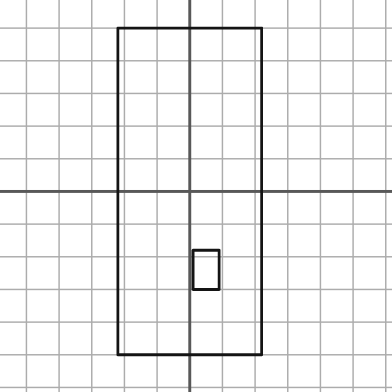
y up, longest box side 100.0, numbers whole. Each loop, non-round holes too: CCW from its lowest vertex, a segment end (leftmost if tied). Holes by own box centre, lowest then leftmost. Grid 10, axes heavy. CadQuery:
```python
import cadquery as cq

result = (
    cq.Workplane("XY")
    .moveTo(-22.0, -50.0)
    .lineTo(22.0, -50.0)
    .lineTo(22.0, 50.0)
    .lineTo(-22.0, 50.0)
    .close()
    .moveTo(1.0, -30.0)
    .lineTo(9.0, -30.0)
    .lineTo(9.0, -18.0)
    .lineTo(1.0, -18.0)
    .close()
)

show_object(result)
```